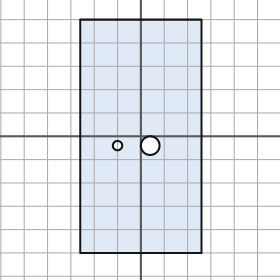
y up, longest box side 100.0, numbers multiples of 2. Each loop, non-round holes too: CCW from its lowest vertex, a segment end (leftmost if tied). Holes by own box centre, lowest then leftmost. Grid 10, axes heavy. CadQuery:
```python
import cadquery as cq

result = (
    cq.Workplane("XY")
    .moveTo(-26.0, -50.0)
    .lineTo(26.0, -50.0)
    .lineTo(26.0, 50.0)
    .lineTo(-26.0, 50.0)
    .close()
    .moveTo(-10.0, -4.0)
    .circle(2.0)
    .moveTo(4.0, -4.0)
    .circle(4.0)
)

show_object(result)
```